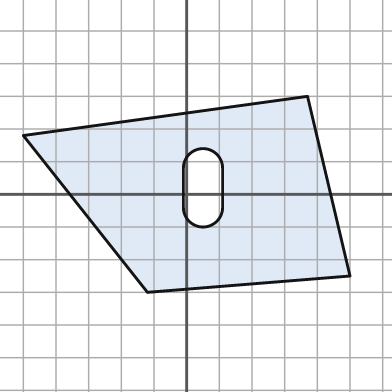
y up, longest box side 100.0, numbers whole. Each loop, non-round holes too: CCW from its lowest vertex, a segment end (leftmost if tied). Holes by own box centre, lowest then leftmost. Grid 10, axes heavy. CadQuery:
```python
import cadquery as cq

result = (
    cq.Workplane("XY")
    .moveTo(-12.0, -30.0)
    .lineTo(50.0, -25.0)
    .lineTo(37.0, 30.0)
    .lineTo(-50.0, 18.0)
    .close()
    .moveTo(-1.0, -4.0)
    .threePointArc((5.0, -10.0), (11.0, -4.0))
    .lineTo(11.0, 8.0)
    .threePointArc((5.0, 14.0), (-1.0, 8.0))
    .close()
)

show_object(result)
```